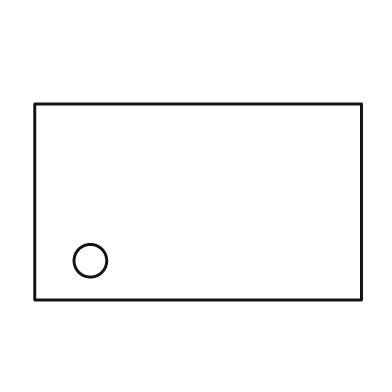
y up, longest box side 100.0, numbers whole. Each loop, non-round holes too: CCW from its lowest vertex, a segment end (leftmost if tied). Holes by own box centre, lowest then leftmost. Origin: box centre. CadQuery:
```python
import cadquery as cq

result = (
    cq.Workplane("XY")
    .moveTo(-50.0, -30.0)
    .lineTo(50.0, -30.0)
    .lineTo(50.0, 30.0)
    .lineTo(-50.0, 30.0)
    .close()
    .moveTo(-33.0, -18.0)
    .circle(5.0)
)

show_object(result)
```